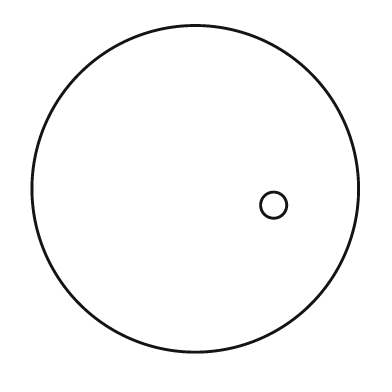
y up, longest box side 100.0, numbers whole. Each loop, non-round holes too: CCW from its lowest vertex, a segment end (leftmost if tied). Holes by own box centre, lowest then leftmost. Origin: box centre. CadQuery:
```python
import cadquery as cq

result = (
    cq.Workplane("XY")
    .moveTo(0.0, 0.0)
    .circle(50.0)
    .moveTo(24.0, -5.0)
    .circle(4.0)
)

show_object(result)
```